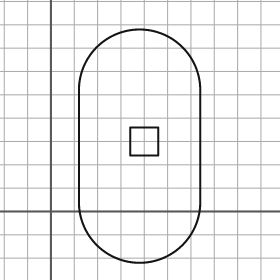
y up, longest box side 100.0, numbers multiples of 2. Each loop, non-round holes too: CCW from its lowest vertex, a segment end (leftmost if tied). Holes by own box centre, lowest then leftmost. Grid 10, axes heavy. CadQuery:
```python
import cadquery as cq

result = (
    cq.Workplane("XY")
    .moveTo(12.0, 4.0)
    .threePointArc((38.0, -22.0), (64.0, 4.0))
    .lineTo(64.0, 52.0)
    .threePointArc((38.0, 78.0), (12.0, 52.0))
    .close()
    .moveTo(34.0, 24.0)
    .lineTo(46.0, 24.0)
    .lineTo(46.0, 36.0)
    .lineTo(34.0, 36.0)
    .close()
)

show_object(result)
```